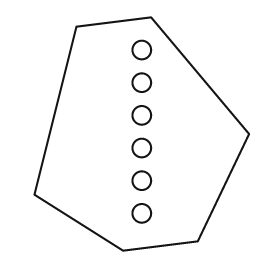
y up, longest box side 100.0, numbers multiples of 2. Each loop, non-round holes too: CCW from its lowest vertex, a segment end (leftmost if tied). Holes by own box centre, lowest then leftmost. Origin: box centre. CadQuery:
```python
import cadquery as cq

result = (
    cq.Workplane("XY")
    .moveTo(-8.0, -50.0)
    .lineTo(24.0, -46.0)
    .lineTo(46.0, 0.0)
    .lineTo(4.0, 50.0)
    .lineTo(-28.0, 46.0)
    .lineTo(-46.0, -26.0)
    .close()
    .moveTo(0.0, -34.0)
    .circle(4.0)
    .moveTo(0.0, -20.0)
    .circle(4.0)
    .moveTo(0.0, -6.0)
    .circle(4.0)
    .moveTo(0.0, 8.0)
    .circle(4.0)
    .moveTo(0.0, 22.0)
    .circle(4.0)
    .moveTo(0.0, 36.0)
    .circle(4.0)
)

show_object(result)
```